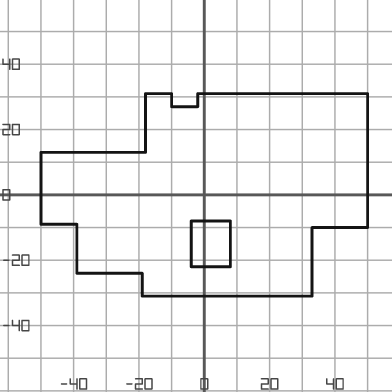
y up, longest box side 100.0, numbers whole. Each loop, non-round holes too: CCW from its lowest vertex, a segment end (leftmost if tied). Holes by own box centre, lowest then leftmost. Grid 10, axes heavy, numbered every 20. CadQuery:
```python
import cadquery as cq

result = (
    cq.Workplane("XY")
    .moveTo(-19.0, -31.0)
    .lineTo(33.0, -31.0)
    .lineTo(33.0, -10.0)
    .lineTo(50.0, -10.0)
    .lineTo(50.0, 31.0)
    .lineTo(-2.0, 31.0)
    .lineTo(-2.0, 27.0)
    .lineTo(-10.0, 27.0)
    .lineTo(-10.0, 31.0)
    .lineTo(-18.0, 31.0)
    .lineTo(-18.0, 13.0)
    .lineTo(-50.0, 13.0)
    .lineTo(-50.0, -9.0)
    .lineTo(-39.0, -9.0)
    .lineTo(-39.0, -24.0)
    .lineTo(-19.0, -24.0)
    .close()
    .moveTo(-4.0, -22.0)
    .lineTo(8.0, -22.0)
    .lineTo(8.0, -8.0)
    .lineTo(-4.0, -8.0)
    .close()
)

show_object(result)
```